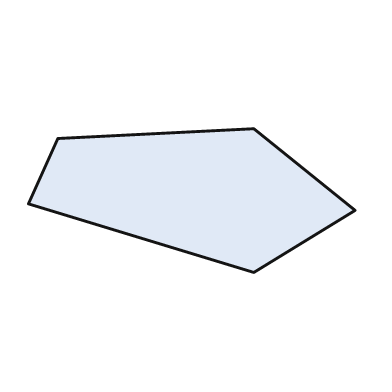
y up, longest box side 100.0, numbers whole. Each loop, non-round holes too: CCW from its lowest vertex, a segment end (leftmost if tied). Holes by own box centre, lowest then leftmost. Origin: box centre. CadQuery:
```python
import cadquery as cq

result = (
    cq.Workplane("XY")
    .moveTo(19.0, -22.0)
    .lineTo(50.0, -3.0)
    .lineTo(19.0, 22.0)
    .lineTo(-41.0, 19.0)
    .lineTo(-50.0, -1.0)
    .close()
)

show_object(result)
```